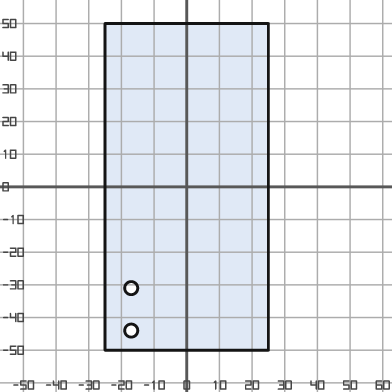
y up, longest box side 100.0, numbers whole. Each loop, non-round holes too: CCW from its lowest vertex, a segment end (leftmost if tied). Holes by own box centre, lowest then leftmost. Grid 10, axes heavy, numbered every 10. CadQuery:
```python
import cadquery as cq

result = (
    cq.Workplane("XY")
    .moveTo(-25.0, -50.0)
    .lineTo(25.0, -50.0)
    .lineTo(25.0, 50.0)
    .lineTo(-25.0, 50.0)
    .close()
    .moveTo(-17.0, -44.0)
    .circle(2.0)
    .moveTo(-17.0, -31.0)
    .circle(2.0)
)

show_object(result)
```